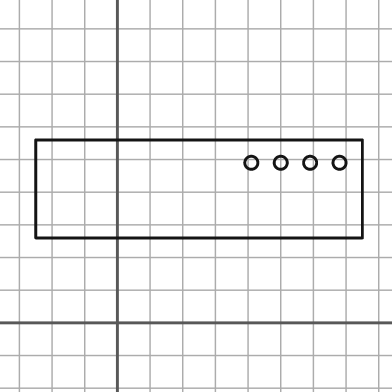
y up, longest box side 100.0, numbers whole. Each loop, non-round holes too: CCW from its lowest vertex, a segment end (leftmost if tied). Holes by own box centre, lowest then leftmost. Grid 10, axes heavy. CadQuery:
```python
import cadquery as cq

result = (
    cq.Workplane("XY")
    .moveTo(-25.0, 26.0)
    .lineTo(75.0, 26.0)
    .lineTo(75.0, 56.0)
    .lineTo(-25.0, 56.0)
    .close()
    .moveTo(41.0, 49.0)
    .circle(2.0)
    .moveTo(50.0, 49.0)
    .circle(2.0)
    .moveTo(59.0, 49.0)
    .circle(2.0)
    .moveTo(68.0, 49.0)
    .circle(2.0)
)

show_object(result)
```